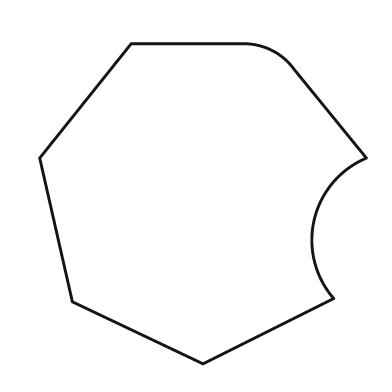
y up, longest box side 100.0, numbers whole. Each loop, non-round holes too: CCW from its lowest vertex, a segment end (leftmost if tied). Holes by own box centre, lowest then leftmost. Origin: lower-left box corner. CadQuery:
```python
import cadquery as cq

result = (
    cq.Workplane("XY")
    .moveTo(50.0, 0.0)
    .lineTo(90.0, 20.0)
    .threePointArc((84.0, 44.0), (100.0, 63.0))
    .lineTo(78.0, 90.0)
    .threePointArc((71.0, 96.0), (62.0, 98.0))
    .lineTo(28.0, 98.0)
    .lineTo(0.0, 63.0)
    .lineTo(10.0, 19.0)
    .close()
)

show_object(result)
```